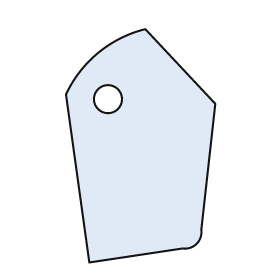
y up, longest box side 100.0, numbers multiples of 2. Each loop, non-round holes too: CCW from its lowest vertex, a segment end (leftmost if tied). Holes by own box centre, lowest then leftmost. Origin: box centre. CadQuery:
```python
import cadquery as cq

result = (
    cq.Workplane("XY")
    .moveTo(-22.0, -50.0)
    .lineTo(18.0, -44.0)
    .threePointArc((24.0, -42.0), (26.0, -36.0))
    .lineTo(32.0, 18.0)
    .lineTo(2.0, 50.0)
    .threePointArc((-18.0, 40.0), (-32.0, 22.0))
    .close()
    .moveTo(-14.0, 20.0)
    .circle(6.0)
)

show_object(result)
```